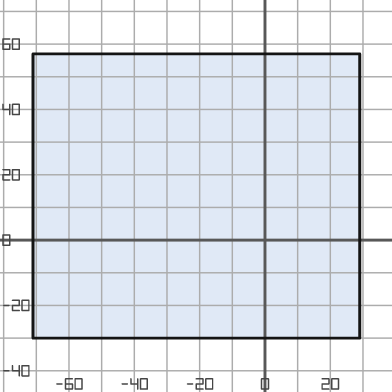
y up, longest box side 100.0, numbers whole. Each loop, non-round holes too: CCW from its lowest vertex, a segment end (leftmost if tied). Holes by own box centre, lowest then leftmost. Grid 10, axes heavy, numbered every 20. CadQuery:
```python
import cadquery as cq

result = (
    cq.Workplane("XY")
    .moveTo(-71.0, -30.0)
    .lineTo(29.0, -30.0)
    .lineTo(29.0, 57.0)
    .lineTo(-71.0, 57.0)
    .close()
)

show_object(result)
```